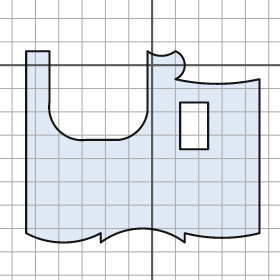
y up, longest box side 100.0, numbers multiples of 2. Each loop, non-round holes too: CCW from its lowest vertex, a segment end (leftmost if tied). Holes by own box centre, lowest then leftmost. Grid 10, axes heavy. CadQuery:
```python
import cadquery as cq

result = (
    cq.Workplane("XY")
    .moveTo(-22.0, -76.0)
    .threePointArc((-4.0, -70.0), (14.0, -76.0))
    .lineTo(14.0, -72.0)
    .threePointArc((30.0, -74.0), (46.0, -72.0))
    .lineTo(46.0, -6.0)
    .threePointArc((28.0, -8.0), (10.0, -6.0))
    .threePointArc((14.0, 0.0), (10.0, 6.0))
    .threePointArc((4.0, 4.0), (-2.0, 6.0))
    .lineTo(-2.0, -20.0)
    .threePointArc((-6.0, -28.0), (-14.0, -32.0))
    .lineTo(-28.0, -32.0)
    .threePointArc((-40.0, -28.0), (-44.0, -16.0))
    .lineTo(-44.0, 6.0)
    .lineTo(-54.0, 6.0)
    .lineTo(-54.0, -72.0)
    .threePointArc((-38.0, -76.0), (-22.0, -72.0))
    .close()
    .moveTo(12.0, -36.0)
    .lineTo(24.0, -36.0)
    .lineTo(24.0, -16.0)
    .lineTo(12.0, -16.0)
    .close()
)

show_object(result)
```